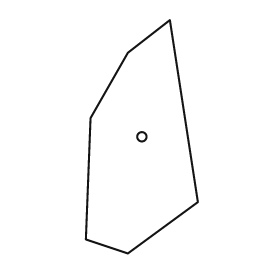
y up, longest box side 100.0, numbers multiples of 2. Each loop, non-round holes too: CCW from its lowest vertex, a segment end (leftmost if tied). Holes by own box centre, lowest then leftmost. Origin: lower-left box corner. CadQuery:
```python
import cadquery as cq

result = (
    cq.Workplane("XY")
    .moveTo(18.0, 0.0)
    .lineTo(48.0, 22.0)
    .lineTo(36.0, 100.0)
    .lineTo(18.0, 86.0)
    .lineTo(2.0, 58.0)
    .lineTo(0.0, 6.0)
    .close()
    .moveTo(24.0, 50.0)
    .circle(2.0)
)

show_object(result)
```